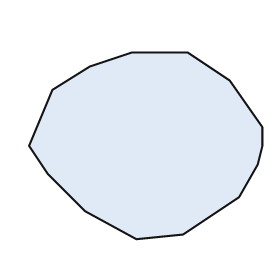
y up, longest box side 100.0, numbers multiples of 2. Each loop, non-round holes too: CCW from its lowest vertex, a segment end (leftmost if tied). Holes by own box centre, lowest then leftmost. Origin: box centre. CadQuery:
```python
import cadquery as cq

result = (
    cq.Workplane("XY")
    .moveTo(-4.0, -40.0)
    .lineTo(16.0, -38.0)
    .lineTo(40.0, -22.0)
    .lineTo(48.0, -8.0)
    .lineTo(50.0, 0.0)
    .lineTo(50.0, 8.0)
    .lineTo(36.0, 28.0)
    .lineTo(18.0, 40.0)
    .lineTo(-6.0, 40.0)
    .lineTo(-24.0, 34.0)
    .lineTo(-40.0, 24.0)
    .lineTo(-50.0, 0.0)
    .lineTo(-42.0, -12.0)
    .lineTo(-26.0, -28.0)
    .close()
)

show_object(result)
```